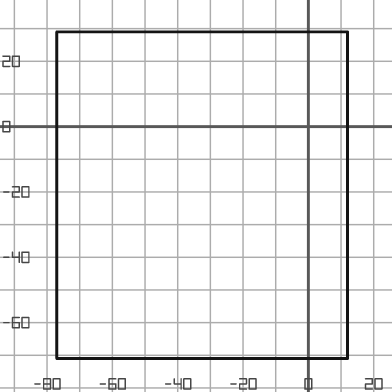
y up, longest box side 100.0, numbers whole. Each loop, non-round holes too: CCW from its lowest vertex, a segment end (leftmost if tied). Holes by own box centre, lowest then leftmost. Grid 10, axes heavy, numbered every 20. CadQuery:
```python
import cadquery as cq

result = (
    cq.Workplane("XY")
    .moveTo(-77.0, -71.0)
    .lineTo(12.0, -71.0)
    .lineTo(12.0, 29.0)
    .lineTo(-77.0, 29.0)
    .close()
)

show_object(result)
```